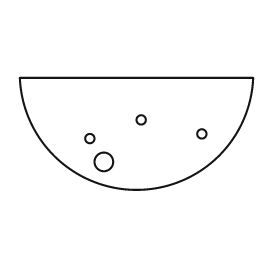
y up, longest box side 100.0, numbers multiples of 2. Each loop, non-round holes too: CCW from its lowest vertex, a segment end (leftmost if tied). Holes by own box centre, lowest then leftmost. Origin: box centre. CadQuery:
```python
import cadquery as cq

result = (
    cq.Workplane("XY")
    .moveTo(-50.0, 24.0)
    .threePointArc((0.0, -24.0), (50.0, 24.0))
    .close()
    .moveTo(-14.0, -12.0)
    .circle(4.0)
    .moveTo(-20.0, -2.0)
    .circle(2.0)
    .moveTo(28.0, 0.0)
    .circle(2.0)
    .moveTo(2.0, 6.0)
    .circle(2.0)
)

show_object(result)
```